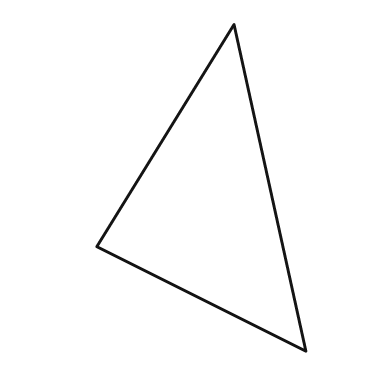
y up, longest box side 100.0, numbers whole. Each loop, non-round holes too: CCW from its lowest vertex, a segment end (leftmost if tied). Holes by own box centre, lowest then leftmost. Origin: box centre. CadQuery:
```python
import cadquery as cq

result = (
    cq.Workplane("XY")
    .moveTo(32.0, -50.0)
    .lineTo(10.0, 50.0)
    .lineTo(-32.0, -18.0)
    .close()
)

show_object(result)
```